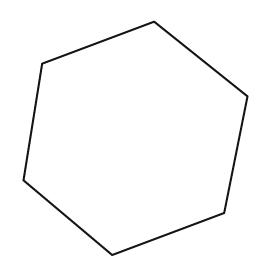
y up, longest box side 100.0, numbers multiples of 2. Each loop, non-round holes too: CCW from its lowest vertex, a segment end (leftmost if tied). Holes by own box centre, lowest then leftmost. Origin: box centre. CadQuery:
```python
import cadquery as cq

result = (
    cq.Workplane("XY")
    .moveTo(-10.0, -50.0)
    .lineTo(38.0, -32.0)
    .lineTo(48.0, 18.0)
    .lineTo(8.0, 50.0)
    .lineTo(-40.0, 32.0)
    .lineTo(-48.0, -18.0)
    .close()
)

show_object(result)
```